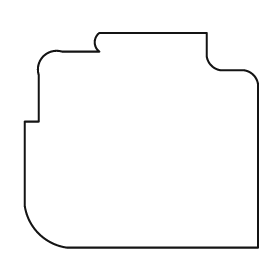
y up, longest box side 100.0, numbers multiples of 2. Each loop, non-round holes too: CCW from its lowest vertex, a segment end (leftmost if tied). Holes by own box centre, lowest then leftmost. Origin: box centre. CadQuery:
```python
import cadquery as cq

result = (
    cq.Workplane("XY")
    .moveTo(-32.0, -46.0)
    .lineTo(50.0, -46.0)
    .lineTo(50.0, 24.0)
    .threePointArc((48.0, 28.0), (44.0, 30.0))
    .lineTo(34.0, 30.0)
    .threePointArc((30.0, 32.0), (28.0, 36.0))
    .lineTo(28.0, 46.0)
    .lineTo(-18.0, 46.0)
    .threePointArc((-20.0, 42.0), (-18.0, 38.0))
    .lineTo(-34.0, 38.0)
    .threePointArc((-42.0, 36.0), (-44.0, 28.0))
    .lineTo(-44.0, 8.0)
    .lineTo(-50.0, 8.0)
    .lineTo(-50.0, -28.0)
    .threePointArc((-44.0, -40.0), (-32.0, -46.0))
    .close()
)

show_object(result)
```